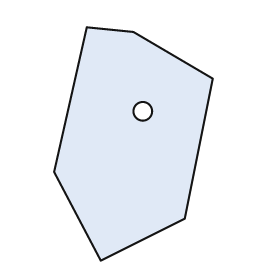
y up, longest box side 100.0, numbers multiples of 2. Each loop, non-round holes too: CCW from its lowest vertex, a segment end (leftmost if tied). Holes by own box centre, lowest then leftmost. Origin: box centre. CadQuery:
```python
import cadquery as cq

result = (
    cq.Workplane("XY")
    .moveTo(-14.0, -50.0)
    .lineTo(22.0, -32.0)
    .lineTo(34.0, 28.0)
    .lineTo(0.0, 48.0)
    .lineTo(-20.0, 50.0)
    .lineTo(-34.0, -12.0)
    .close()
    .moveTo(4.0, 14.0)
    .circle(4.0)
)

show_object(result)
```